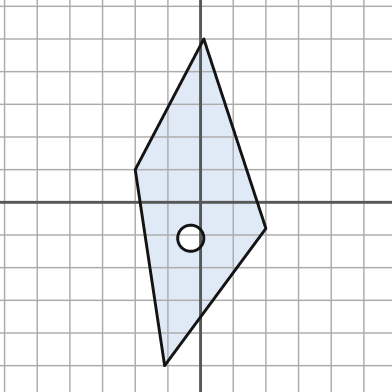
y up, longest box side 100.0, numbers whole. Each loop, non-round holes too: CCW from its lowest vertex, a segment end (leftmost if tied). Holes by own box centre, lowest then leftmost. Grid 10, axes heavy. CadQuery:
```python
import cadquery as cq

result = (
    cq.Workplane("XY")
    .moveTo(-11.0, -50.0)
    .lineTo(20.0, -8.0)
    .lineTo(1.0, 50.0)
    .lineTo(-20.0, 10.0)
    .close()
    .moveTo(-3.0, -11.0)
    .circle(4.0)
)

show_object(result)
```